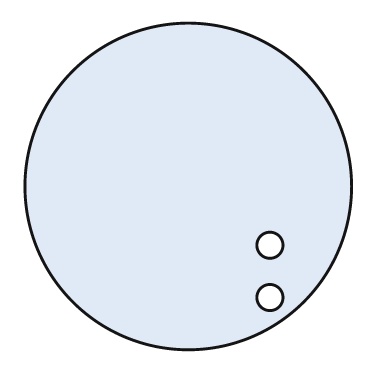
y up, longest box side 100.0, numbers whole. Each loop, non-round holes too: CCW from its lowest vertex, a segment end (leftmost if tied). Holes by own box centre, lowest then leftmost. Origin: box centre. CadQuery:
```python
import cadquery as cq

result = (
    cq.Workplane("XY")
    .moveTo(0.0, 0.0)
    .circle(50.0)
    .moveTo(25.0, -34.0)
    .circle(4.0)
    .moveTo(25.0, -18.0)
    .circle(4.0)
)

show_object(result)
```